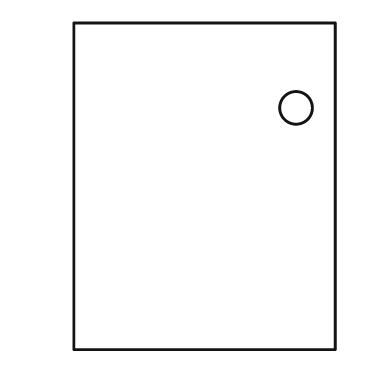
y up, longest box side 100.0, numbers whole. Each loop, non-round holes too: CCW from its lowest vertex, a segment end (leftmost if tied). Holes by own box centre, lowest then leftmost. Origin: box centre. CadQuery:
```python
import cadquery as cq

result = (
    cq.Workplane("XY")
    .moveTo(-40.0, -50.0)
    .lineTo(40.0, -50.0)
    .lineTo(40.0, 50.0)
    .lineTo(-40.0, 50.0)
    .close()
    .moveTo(28.0, 24.0)
    .circle(5.0)
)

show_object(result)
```